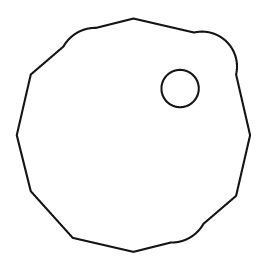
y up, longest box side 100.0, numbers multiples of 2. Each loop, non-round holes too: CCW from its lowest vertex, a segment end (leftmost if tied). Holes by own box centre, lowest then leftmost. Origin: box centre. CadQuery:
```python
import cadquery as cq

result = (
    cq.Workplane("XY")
    .moveTo(0.0, -50.0)
    .lineTo(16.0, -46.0)
    .threePointArc((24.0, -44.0), (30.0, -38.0))
    .lineTo(44.0, -26.0)
    .lineTo(50.0, 0.0)
    .lineTo(44.0, 26.0)
    .threePointArc((40.0, 40.0), (26.0, 44.0))
    .lineTo(0.0, 50.0)
    .lineTo(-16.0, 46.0)
    .threePointArc((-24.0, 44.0), (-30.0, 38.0))
    .lineTo(-44.0, 26.0)
    .lineTo(-50.0, 0.0)
    .lineTo(-44.0, -24.0)
    .lineTo(-26.0, -44.0)
    .close()
    .moveTo(20.0, 20.0)
    .circle(8.0)
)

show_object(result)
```